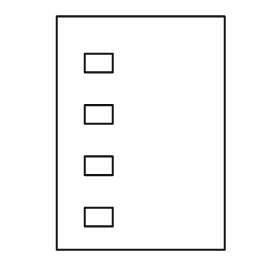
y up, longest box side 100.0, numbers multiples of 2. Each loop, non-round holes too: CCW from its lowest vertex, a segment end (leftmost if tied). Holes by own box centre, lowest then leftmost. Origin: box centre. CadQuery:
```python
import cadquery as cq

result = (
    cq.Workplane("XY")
    .moveTo(-36.0, -50.0)
    .lineTo(36.0, -50.0)
    .lineTo(36.0, 50.0)
    .lineTo(-36.0, 50.0)
    .close()
    .moveTo(-24.0, -40.0)
    .lineTo(-12.0, -40.0)
    .lineTo(-12.0, -32.0)
    .lineTo(-24.0, -32.0)
    .close()
    .moveTo(-24.0, -18.0)
    .lineTo(-12.0, -18.0)
    .lineTo(-12.0, -10.0)
    .lineTo(-24.0, -10.0)
    .close()
    .moveTo(-24.0, 4.0)
    .lineTo(-12.0, 4.0)
    .lineTo(-12.0, 12.0)
    .lineTo(-24.0, 12.0)
    .close()
    .moveTo(-24.0, 26.0)
    .lineTo(-12.0, 26.0)
    .lineTo(-12.0, 34.0)
    .lineTo(-24.0, 34.0)
    .close()
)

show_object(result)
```